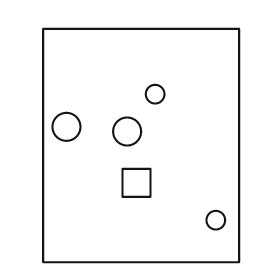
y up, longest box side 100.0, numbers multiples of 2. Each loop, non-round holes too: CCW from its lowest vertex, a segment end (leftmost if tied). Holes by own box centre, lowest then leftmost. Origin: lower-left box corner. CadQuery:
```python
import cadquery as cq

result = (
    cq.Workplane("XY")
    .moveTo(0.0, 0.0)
    .lineTo(84.0, 0.0)
    .lineTo(84.0, 100.0)
    .lineTo(0.0, 100.0)
    .close()
    .moveTo(74.0, 18.0)
    .circle(4.0)
    .moveTo(34.0, 28.0)
    .lineTo(46.0, 28.0)
    .lineTo(46.0, 40.0)
    .lineTo(34.0, 40.0)
    .close()
    .moveTo(36.0, 56.0)
    .circle(6.0)
    .moveTo(10.0, 58.0)
    .circle(6.0)
    .moveTo(48.0, 72.0)
    .circle(4.0)
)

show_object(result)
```